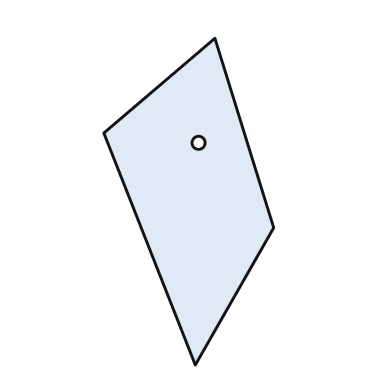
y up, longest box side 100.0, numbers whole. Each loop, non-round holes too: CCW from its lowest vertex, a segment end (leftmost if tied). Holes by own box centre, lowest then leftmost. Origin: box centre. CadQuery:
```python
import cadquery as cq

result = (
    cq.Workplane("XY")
    .moveTo(2.0, -50.0)
    .lineTo(26.0, -8.0)
    .lineTo(8.0, 50.0)
    .lineTo(-26.0, 21.0)
    .close()
    .moveTo(3.0, 18.0)
    .circle(2.0)
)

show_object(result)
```